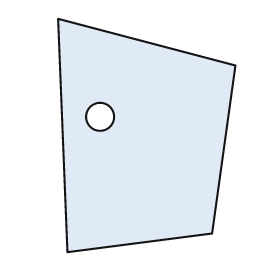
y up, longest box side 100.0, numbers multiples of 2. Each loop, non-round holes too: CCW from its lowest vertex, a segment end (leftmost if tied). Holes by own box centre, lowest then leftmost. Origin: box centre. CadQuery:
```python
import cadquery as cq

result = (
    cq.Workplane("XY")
    .moveTo(-34.0, -50.0)
    .lineTo(28.0, -42.0)
    .lineTo(38.0, 30.0)
    .lineTo(-38.0, 50.0)
    .close()
    .moveTo(-20.0, 8.0)
    .circle(6.0)
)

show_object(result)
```